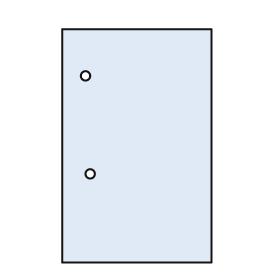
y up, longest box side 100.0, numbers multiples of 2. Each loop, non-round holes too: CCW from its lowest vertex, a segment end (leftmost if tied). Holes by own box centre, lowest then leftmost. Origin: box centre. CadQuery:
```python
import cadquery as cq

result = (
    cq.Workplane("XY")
    .moveTo(-32.0, -50.0)
    .lineTo(32.0, -50.0)
    .lineTo(32.0, 50.0)
    .lineTo(-32.0, 50.0)
    .close()
    .moveTo(-20.0, -12.0)
    .circle(2.0)
    .moveTo(-22.0, 30.0)
    .circle(2.0)
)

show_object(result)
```